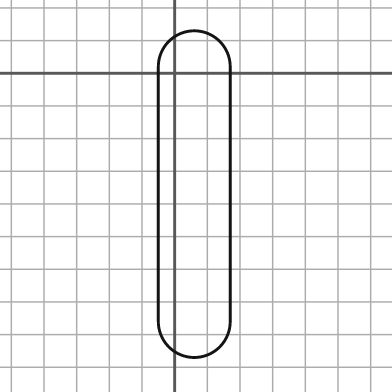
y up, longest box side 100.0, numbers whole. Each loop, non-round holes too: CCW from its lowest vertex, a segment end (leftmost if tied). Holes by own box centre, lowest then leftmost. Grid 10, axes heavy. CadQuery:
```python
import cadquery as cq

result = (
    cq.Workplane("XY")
    .moveTo(-5.0, -76.0)
    .threePointArc((6.0, -87.0), (17.0, -76.0))
    .lineTo(17.0, 2.0)
    .threePointArc((6.0, 13.0), (-5.0, 2.0))
    .close()
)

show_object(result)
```